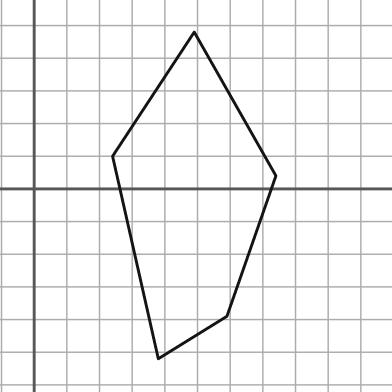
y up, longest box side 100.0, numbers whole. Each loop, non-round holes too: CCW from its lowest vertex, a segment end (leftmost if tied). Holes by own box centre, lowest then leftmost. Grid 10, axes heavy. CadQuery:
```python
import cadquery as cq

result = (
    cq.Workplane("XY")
    .moveTo(38.0, -52.0)
    .lineTo(59.0, -39.0)
    .lineTo(74.0, 4.0)
    .lineTo(49.0, 48.0)
    .lineTo(24.0, 10.0)
    .close()
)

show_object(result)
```